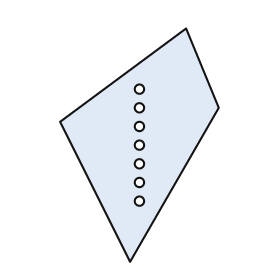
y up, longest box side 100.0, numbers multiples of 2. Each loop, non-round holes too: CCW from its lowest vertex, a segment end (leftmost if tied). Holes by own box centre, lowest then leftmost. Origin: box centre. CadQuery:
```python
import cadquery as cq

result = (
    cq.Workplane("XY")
    .moveTo(-4.0, -50.0)
    .lineTo(34.0, 16.0)
    .lineTo(20.0, 50.0)
    .lineTo(-34.0, 10.0)
    .close()
    .moveTo(0.0, -24.0)
    .circle(2.0)
    .moveTo(0.0, -16.0)
    .circle(2.0)
    .moveTo(0.0, -8.0)
    .circle(2.0)
    .moveTo(0.0, 0.0)
    .circle(2.0)
    .moveTo(0.0, 8.0)
    .circle(2.0)
    .moveTo(0.0, 16.0)
    .circle(2.0)
    .moveTo(0.0, 24.0)
    .circle(2.0)
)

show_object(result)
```